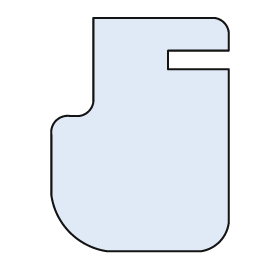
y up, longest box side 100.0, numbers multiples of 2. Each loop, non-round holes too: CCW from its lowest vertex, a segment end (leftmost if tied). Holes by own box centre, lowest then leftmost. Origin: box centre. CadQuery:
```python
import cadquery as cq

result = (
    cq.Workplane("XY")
    .moveTo(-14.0, -50.0)
    .lineTo(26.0, -50.0)
    .threePointArc((34.0, -46.0), (38.0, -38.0))
    .lineTo(38.0, 28.0)
    .lineTo(12.0, 28.0)
    .lineTo(12.0, 36.0)
    .lineTo(38.0, 36.0)
    .lineTo(38.0, 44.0)
    .threePointArc((36.0, 48.0), (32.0, 50.0))
    .lineTo(-20.0, 50.0)
    .lineTo(-20.0, 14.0)
    .threePointArc((-22.0, 10.0), (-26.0, 8.0))
    .lineTo(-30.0, 8.0)
    .threePointArc((-36.0, 6.0), (-38.0, 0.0))
    .lineTo(-38.0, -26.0)
    .threePointArc((-30.0, -42.0), (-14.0, -50.0))
    .close()
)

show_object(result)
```